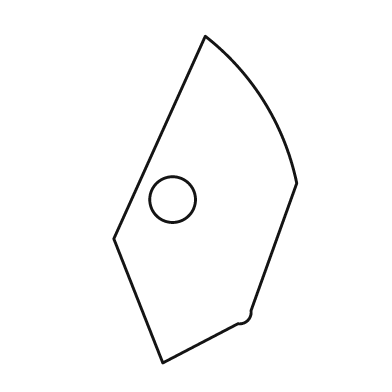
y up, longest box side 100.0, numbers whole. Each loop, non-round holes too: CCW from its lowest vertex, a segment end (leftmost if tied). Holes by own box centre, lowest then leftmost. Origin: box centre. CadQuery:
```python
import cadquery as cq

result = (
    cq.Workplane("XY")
    .moveTo(-13.0, -50.0)
    .lineTo(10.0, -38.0)
    .threePointArc((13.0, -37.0), (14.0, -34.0))
    .lineTo(28.0, 5.0)
    .threePointArc((18.0, 30.0), (0.0, 50.0))
    .lineTo(-28.0, -12.0)
    .close()
    .moveTo(-10.0, 0.0)
    .circle(7.0)
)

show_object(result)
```